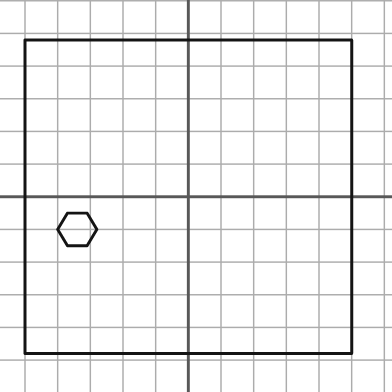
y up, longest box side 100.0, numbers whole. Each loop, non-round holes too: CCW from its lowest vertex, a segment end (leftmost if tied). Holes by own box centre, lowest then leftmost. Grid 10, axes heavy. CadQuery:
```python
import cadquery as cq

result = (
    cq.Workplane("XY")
    .moveTo(-50.0, -48.0)
    .lineTo(50.0, -48.0)
    .lineTo(50.0, 48.0)
    .lineTo(-50.0, 48.0)
    .close()
    .moveTo(-37.0, -15.0)
    .lineTo(-31.0, -15.0)
    .lineTo(-28.0, -10.0)
    .lineTo(-31.0, -5.0)
    .lineTo(-37.0, -5.0)
    .lineTo(-40.0, -10.0)
    .close()
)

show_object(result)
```